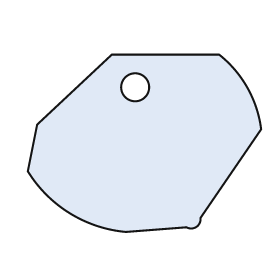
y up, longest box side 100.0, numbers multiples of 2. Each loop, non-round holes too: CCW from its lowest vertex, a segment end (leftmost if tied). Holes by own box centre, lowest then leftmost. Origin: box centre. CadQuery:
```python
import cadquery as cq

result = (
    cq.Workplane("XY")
    .moveTo(-8.0, -38.0)
    .lineTo(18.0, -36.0)
    .threePointArc((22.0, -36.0), (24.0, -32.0))
    .lineTo(50.0, 6.0)
    .threePointArc((44.0, 24.0), (32.0, 38.0))
    .lineTo(-14.0, 38.0)
    .lineTo(-46.0, 8.0)
    .lineTo(-50.0, -12.0)
    .threePointArc((-32.0, -30.0), (-8.0, -38.0))
    .close()
    .moveTo(-4.0, 24.0)
    .circle(6.0)
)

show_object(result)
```